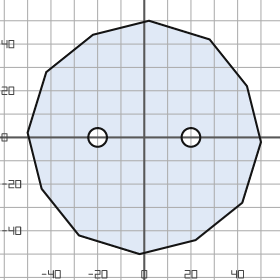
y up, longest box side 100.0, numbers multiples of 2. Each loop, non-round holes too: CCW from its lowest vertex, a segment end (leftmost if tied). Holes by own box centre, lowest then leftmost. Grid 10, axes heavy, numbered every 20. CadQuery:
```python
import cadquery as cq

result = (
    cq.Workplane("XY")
    .moveTo(-2.0, -50.0)
    .lineTo(22.0, -44.0)
    .lineTo(42.0, -28.0)
    .lineTo(50.0, -2.0)
    .lineTo(44.0, 22.0)
    .lineTo(28.0, 42.0)
    .lineTo(2.0, 50.0)
    .lineTo(-22.0, 44.0)
    .lineTo(-42.0, 28.0)
    .lineTo(-50.0, 2.0)
    .lineTo(-44.0, -22.0)
    .lineTo(-28.0, -42.0)
    .close()
    .moveTo(-20.0, 0.0)
    .circle(4.0)
    .moveTo(20.0, 0.0)
    .circle(4.0)
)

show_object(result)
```